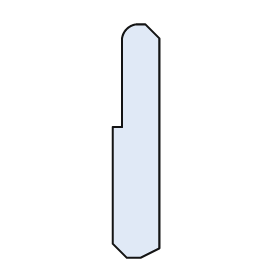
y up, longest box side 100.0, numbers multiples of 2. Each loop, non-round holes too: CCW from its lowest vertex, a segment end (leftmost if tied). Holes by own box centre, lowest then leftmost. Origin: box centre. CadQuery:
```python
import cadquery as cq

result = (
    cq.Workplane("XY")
    .moveTo(-4.0, -50.0)
    .lineTo(2.0, -50.0)
    .lineTo(10.0, -46.0)
    .lineTo(10.0, 44.0)
    .lineTo(4.0, 50.0)
    .lineTo(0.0, 50.0)
    .threePointArc((-4.0, 48.0), (-6.0, 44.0))
    .lineTo(-6.0, 6.0)
    .lineTo(-10.0, 6.0)
    .lineTo(-10.0, -44.0)
    .close()
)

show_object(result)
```